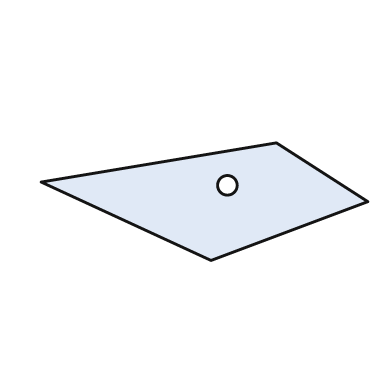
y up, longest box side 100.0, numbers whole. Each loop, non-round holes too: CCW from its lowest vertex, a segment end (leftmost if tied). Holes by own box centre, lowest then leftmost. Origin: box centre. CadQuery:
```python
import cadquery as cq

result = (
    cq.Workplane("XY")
    .moveTo(2.0, -18.0)
    .lineTo(50.0, 0.0)
    .lineTo(22.0, 18.0)
    .lineTo(-50.0, 6.0)
    .close()
    .moveTo(7.0, 5.0)
    .circle(3.0)
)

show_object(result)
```